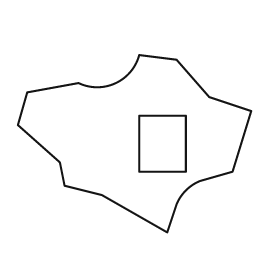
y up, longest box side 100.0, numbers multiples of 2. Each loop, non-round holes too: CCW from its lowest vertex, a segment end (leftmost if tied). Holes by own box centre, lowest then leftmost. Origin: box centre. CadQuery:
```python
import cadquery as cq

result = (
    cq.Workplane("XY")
    .moveTo(14.0, -38.0)
    .lineTo(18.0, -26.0)
    .threePointArc((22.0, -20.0), (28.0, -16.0))
    .lineTo(42.0, -12.0)
    .lineTo(50.0, 14.0)
    .lineTo(32.0, 20.0)
    .lineTo(18.0, 36.0)
    .lineTo(2.0, 38.0)
    .threePointArc((-8.0, 26.0), (-24.0, 26.0))
    .lineTo(-46.0, 22.0)
    .lineTo(-50.0, 8.0)
    .lineTo(-32.0, -8.0)
    .lineTo(-30.0, -18.0)
    .lineTo(-14.0, -22.0)
    .close()
    .moveTo(2.0, -12.0)
    .lineTo(22.0, -12.0)
    .lineTo(22.0, 12.0)
    .lineTo(2.0, 12.0)
    .close()
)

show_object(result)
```